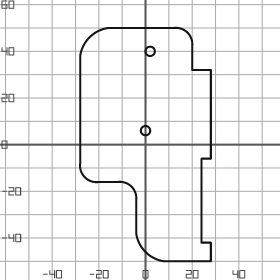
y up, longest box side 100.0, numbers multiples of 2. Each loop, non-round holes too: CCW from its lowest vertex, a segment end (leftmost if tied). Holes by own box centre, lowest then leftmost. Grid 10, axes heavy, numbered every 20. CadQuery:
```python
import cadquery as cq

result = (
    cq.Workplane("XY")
    .moveTo(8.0, -50.0)
    .lineTo(28.0, -50.0)
    .lineTo(28.0, -42.0)
    .lineTo(24.0, -42.0)
    .lineTo(24.0, -6.0)
    .lineTo(28.0, -6.0)
    .lineTo(28.0, 32.0)
    .lineTo(20.0, 32.0)
    .lineTo(20.0, 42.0)
    .threePointArc((18.0, 48.0), (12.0, 50.0))
    .lineTo(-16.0, 50.0)
    .threePointArc((-24.0, 46.0), (-28.0, 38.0))
    .lineTo(-28.0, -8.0)
    .threePointArc((-26.0, -14.0), (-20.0, -16.0))
    .lineTo(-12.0, -16.0)
    .threePointArc((-6.0, -18.0), (-4.0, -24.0))
    .lineTo(-4.0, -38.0)
    .threePointArc((0.0, -46.0), (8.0, -50.0))
    .close()
    .moveTo(0.0, 6.0)
    .circle(2.0)
    .moveTo(2.0, 40.0)
    .circle(2.0)
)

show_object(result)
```